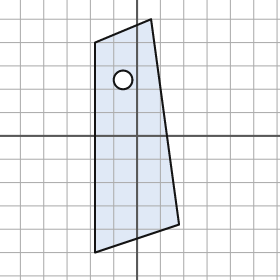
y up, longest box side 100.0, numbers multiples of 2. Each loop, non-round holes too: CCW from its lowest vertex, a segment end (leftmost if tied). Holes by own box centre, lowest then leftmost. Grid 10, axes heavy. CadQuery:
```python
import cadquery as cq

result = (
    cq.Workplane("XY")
    .moveTo(-18.0, -50.0)
    .lineTo(18.0, -38.0)
    .lineTo(6.0, 50.0)
    .lineTo(-18.0, 40.0)
    .close()
    .moveTo(-6.0, 24.0)
    .circle(4.0)
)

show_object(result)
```